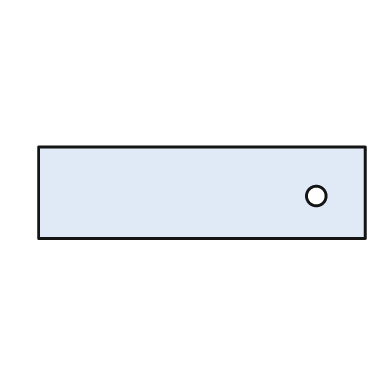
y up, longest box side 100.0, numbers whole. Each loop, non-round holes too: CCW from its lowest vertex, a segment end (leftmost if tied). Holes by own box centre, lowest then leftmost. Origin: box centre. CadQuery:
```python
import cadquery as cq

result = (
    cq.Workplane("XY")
    .moveTo(-50.0, -14.0)
    .lineTo(50.0, -14.0)
    .lineTo(50.0, 14.0)
    .lineTo(-50.0, 14.0)
    .close()
    .moveTo(35.0, -1.0)
    .circle(3.0)
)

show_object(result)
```